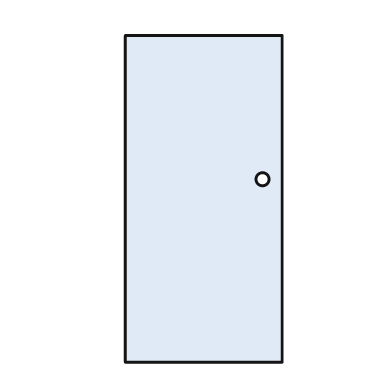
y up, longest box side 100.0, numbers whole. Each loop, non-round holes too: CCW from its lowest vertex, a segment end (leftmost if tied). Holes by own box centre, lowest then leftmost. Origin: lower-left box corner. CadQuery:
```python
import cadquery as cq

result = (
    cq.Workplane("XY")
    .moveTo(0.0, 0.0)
    .lineTo(48.0, 0.0)
    .lineTo(48.0, 100.0)
    .lineTo(0.0, 100.0)
    .close()
    .moveTo(42.0, 56.0)
    .circle(2.0)
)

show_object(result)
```